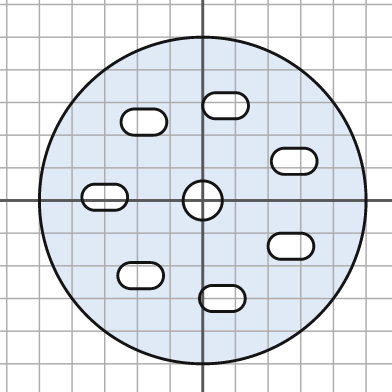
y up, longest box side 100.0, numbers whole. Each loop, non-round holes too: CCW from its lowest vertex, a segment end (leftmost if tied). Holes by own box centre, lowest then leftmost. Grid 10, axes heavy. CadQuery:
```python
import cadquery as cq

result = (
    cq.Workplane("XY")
    .moveTo(0.0, 0.0)
    .circle(50.0)
    .moveTo(3.0, -34.0)
    .lineTo(9.0, -34.0)
    .threePointArc((13.0, -30.0), (9.0, -26.0))
    .lineTo(3.0, -26.0)
    .threePointArc((-1.0, -30.0), (3.0, -34.0))
    .close()
    .moveTo(-22.0, -27.0)
    .lineTo(-16.0, -27.0)
    .threePointArc((-12.0, -23.0), (-16.0, -19.0))
    .lineTo(-22.0, -19.0)
    .threePointArc((-26.0, -23.0), (-22.0, -27.0))
    .close()
    .moveTo(24.0, -18.0)
    .lineTo(30.0, -18.0)
    .threePointArc((34.0, -14.0), (30.0, -10.0))
    .lineTo(24.0, -10.0)
    .threePointArc((20.0, -14.0), (24.0, -18.0))
    .close()
    .moveTo(0.0, 0.0)
    .circle(6.0)
    .moveTo(-33.0, -3.0)
    .lineTo(-27.0, -3.0)
    .threePointArc((-23.0, 1.0), (-27.0, 5.0))
    .lineTo(-33.0, 5.0)
    .threePointArc((-37.0, 1.0), (-33.0, -3.0))
    .close()
    .moveTo(25.0, 8.0)
    .lineTo(31.0, 8.0)
    .threePointArc((35.0, 12.0), (31.0, 16.0))
    .lineTo(25.0, 16.0)
    .threePointArc((21.0, 12.0), (25.0, 8.0))
    .close()
    .moveTo(-21.0, 20.0)
    .lineTo(-15.0, 20.0)
    .threePointArc((-11.0, 24.0), (-15.0, 28.0))
    .lineTo(-21.0, 28.0)
    .threePointArc((-25.0, 24.0), (-21.0, 20.0))
    .close()
    .moveTo(4.0, 25.0)
    .lineTo(10.0, 25.0)
    .threePointArc((14.0, 29.0), (10.0, 33.0))
    .lineTo(4.0, 33.0)
    .threePointArc((0.0, 29.0), (4.0, 25.0))
    .close()
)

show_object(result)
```